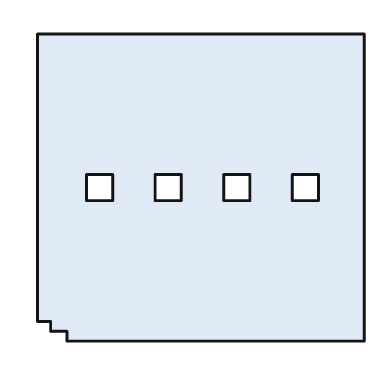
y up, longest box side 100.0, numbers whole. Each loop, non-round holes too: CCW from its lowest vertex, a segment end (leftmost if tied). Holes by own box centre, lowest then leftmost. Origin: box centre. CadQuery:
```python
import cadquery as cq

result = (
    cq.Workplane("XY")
    .moveTo(-41.0, -47.0)
    .lineTo(50.0, -47.0)
    .lineTo(50.0, 47.0)
    .lineTo(-50.0, 47.0)
    .lineTo(-50.0, -41.0)
    .lineTo(-46.0, -41.0)
    .lineTo(-46.0, -44.0)
    .lineTo(-41.0, -44.0)
    .close()
    .moveTo(-35.0, -4.0)
    .lineTo(-27.0, -4.0)
    .lineTo(-27.0, 4.0)
    .lineTo(-35.0, 4.0)
    .close()
    .moveTo(-14.0, -4.0)
    .lineTo(-6.0, -4.0)
    .lineTo(-6.0, 4.0)
    .lineTo(-14.0, 4.0)
    .close()
    .moveTo(7.0, -4.0)
    .lineTo(15.0, -4.0)
    .lineTo(15.0, 4.0)
    .lineTo(7.0, 4.0)
    .close()
    .moveTo(28.0, -4.0)
    .lineTo(36.0, -4.0)
    .lineTo(36.0, 4.0)
    .lineTo(28.0, 4.0)
    .close()
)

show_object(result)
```